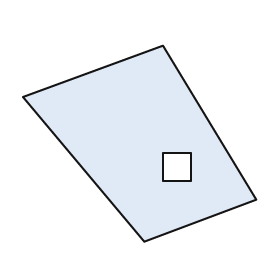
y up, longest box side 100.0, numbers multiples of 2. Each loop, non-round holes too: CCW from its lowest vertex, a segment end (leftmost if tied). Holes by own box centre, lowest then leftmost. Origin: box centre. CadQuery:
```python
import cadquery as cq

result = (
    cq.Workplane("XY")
    .moveTo(2.0, -42.0)
    .lineTo(50.0, -24.0)
    .lineTo(10.0, 42.0)
    .lineTo(-50.0, 20.0)
    .close()
    .moveTo(10.0, -16.0)
    .lineTo(22.0, -16.0)
    .lineTo(22.0, -4.0)
    .lineTo(10.0, -4.0)
    .close()
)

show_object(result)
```